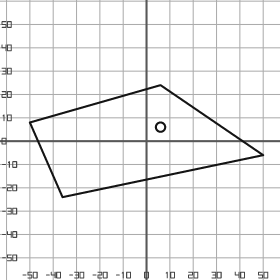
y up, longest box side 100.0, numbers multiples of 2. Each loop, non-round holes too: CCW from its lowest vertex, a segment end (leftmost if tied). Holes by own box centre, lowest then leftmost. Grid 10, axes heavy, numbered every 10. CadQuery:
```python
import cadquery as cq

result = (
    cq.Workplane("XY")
    .moveTo(-36.0, -24.0)
    .lineTo(50.0, -6.0)
    .lineTo(6.0, 24.0)
    .lineTo(-50.0, 8.0)
    .close()
    .moveTo(6.0, 6.0)
    .circle(2.0)
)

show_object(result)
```